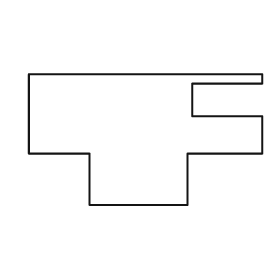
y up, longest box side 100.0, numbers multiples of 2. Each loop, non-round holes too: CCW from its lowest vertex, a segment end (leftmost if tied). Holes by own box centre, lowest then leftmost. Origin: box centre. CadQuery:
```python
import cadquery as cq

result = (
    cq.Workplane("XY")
    .moveTo(-24.0, -28.0)
    .lineTo(18.0, -28.0)
    .lineTo(18.0, -6.0)
    .lineTo(50.0, -6.0)
    .lineTo(50.0, 10.0)
    .lineTo(20.0, 10.0)
    .lineTo(20.0, 24.0)
    .lineTo(50.0, 24.0)
    .lineTo(50.0, 28.0)
    .lineTo(-50.0, 28.0)
    .lineTo(-50.0, -6.0)
    .lineTo(-24.0, -6.0)
    .close()
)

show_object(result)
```